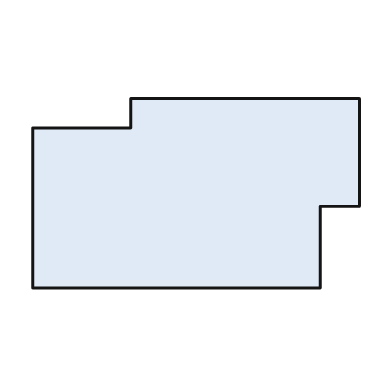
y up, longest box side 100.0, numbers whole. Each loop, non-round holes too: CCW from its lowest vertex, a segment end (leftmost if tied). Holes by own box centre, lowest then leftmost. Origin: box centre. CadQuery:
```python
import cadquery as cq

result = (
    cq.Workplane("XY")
    .moveTo(-50.0, -29.0)
    .lineTo(38.0, -29.0)
    .lineTo(38.0, -4.0)
    .lineTo(50.0, -4.0)
    .lineTo(50.0, 29.0)
    .lineTo(-20.0, 29.0)
    .lineTo(-20.0, 20.0)
    .lineTo(-50.0, 20.0)
    .close()
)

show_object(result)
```